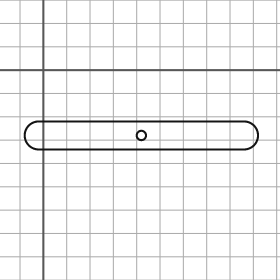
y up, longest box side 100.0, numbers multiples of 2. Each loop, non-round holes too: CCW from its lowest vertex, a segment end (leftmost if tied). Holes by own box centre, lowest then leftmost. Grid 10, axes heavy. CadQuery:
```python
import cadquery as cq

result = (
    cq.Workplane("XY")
    .moveTo(-2.0, -34.0)
    .lineTo(86.0, -34.0)
    .threePointArc((92.0, -28.0), (86.0, -22.0))
    .lineTo(-2.0, -22.0)
    .threePointArc((-8.0, -28.0), (-2.0, -34.0))
    .close()
    .moveTo(42.0, -28.0)
    .circle(2.0)
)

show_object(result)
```